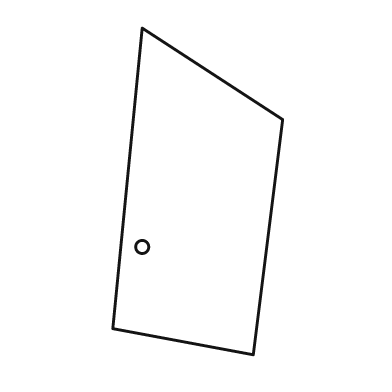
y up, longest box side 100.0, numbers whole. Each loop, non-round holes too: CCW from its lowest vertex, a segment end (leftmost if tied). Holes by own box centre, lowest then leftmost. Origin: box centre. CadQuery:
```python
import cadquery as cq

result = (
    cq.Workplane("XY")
    .moveTo(17.0, -50.0)
    .lineTo(26.0, 22.0)
    .lineTo(-17.0, 50.0)
    .lineTo(-26.0, -42.0)
    .close()
    .moveTo(-17.0, -17.0)
    .circle(2.0)
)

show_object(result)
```